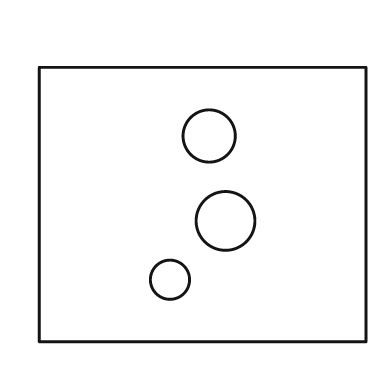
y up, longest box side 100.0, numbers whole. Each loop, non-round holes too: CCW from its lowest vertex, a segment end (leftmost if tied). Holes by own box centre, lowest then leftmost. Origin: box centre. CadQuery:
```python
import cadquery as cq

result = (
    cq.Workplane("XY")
    .moveTo(-50.0, -42.0)
    .lineTo(50.0, -42.0)
    .lineTo(50.0, 42.0)
    .lineTo(-50.0, 42.0)
    .close()
    .moveTo(-10.0, -23.0)
    .circle(6.0)
    .moveTo(7.0, -5.0)
    .circle(9.0)
    .moveTo(2.0, 21.0)
    .circle(8.0)
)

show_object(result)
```